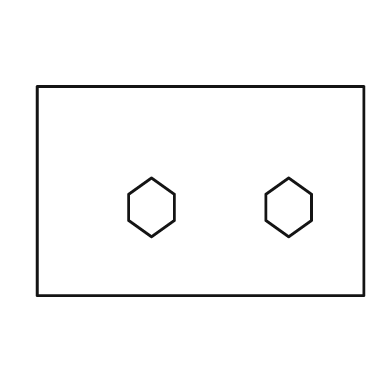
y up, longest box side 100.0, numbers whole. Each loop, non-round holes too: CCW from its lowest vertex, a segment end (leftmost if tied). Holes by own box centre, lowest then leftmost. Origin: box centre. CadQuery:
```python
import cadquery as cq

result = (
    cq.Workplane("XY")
    .moveTo(-50.0, -32.0)
    .lineTo(50.0, -32.0)
    .lineTo(50.0, 32.0)
    .lineTo(-50.0, 32.0)
    .close()
    .moveTo(-15.0, -14.0)
    .lineTo(-8.0, -9.0)
    .lineTo(-8.0, -1.0)
    .lineTo(-15.0, 4.0)
    .lineTo(-22.0, -1.0)
    .lineTo(-22.0, -9.0)
    .close()
    .moveTo(27.0, -14.0)
    .lineTo(34.0, -9.0)
    .lineTo(34.0, -1.0)
    .lineTo(27.0, 4.0)
    .lineTo(20.0, -1.0)
    .lineTo(20.0, -9.0)
    .close()
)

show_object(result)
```